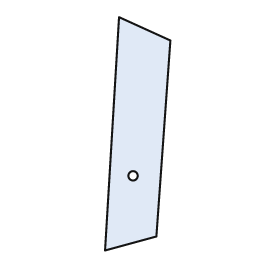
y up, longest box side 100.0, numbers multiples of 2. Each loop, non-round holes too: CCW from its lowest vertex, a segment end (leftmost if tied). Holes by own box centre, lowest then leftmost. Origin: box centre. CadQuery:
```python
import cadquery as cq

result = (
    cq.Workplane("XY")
    .moveTo(-14.0, -50.0)
    .lineTo(8.0, -44.0)
    .lineTo(14.0, 40.0)
    .lineTo(-8.0, 50.0)
    .close()
    .moveTo(-2.0, -18.0)
    .circle(2.0)
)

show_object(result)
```